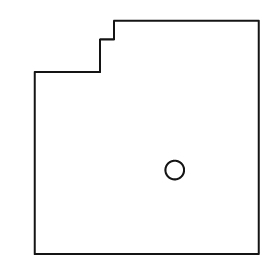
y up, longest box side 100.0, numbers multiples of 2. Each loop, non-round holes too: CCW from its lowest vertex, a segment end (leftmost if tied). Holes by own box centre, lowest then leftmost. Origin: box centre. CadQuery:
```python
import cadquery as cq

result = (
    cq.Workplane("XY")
    .moveTo(-48.0, -50.0)
    .lineTo(48.0, -50.0)
    .lineTo(48.0, 50.0)
    .lineTo(-14.0, 50.0)
    .lineTo(-14.0, 42.0)
    .lineTo(-20.0, 42.0)
    .lineTo(-20.0, 28.0)
    .lineTo(-48.0, 28.0)
    .close()
    .moveTo(12.0, -14.0)
    .circle(4.0)
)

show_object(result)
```